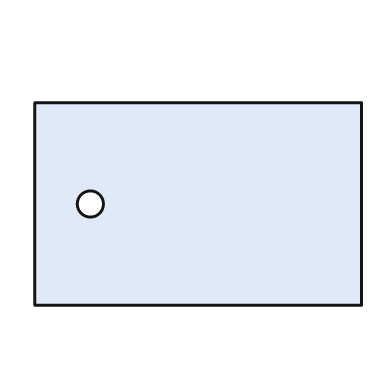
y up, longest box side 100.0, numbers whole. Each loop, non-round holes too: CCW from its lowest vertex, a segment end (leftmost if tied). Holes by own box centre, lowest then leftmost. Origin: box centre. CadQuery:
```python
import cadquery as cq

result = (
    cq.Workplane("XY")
    .moveTo(-50.0, -31.0)
    .lineTo(50.0, -31.0)
    .lineTo(50.0, 31.0)
    .lineTo(-50.0, 31.0)
    .close()
    .moveTo(-33.0, 0.0)
    .circle(4.0)
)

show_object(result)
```